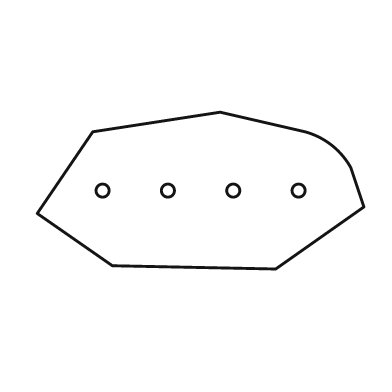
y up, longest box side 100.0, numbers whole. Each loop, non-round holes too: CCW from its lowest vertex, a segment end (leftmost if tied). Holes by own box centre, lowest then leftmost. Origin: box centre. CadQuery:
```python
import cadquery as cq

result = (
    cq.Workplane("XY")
    .moveTo(23.0, -24.0)
    .lineTo(50.0, -5.0)
    .lineTo(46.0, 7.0)
    .threePointArc((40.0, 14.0), (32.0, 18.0))
    .lineTo(6.0, 24.0)
    .lineTo(-33.0, 18.0)
    .lineTo(-50.0, -7.0)
    .lineTo(-27.0, -23.0)
    .close()
    .moveTo(-30.0, 0.0)
    .circle(2.0)
    .moveTo(-10.0, 0.0)
    .circle(2.0)
    .moveTo(10.0, 0.0)
    .circle(2.0)
    .moveTo(30.0, 0.0)
    .circle(2.0)
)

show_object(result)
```